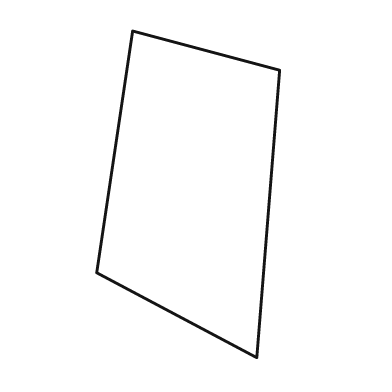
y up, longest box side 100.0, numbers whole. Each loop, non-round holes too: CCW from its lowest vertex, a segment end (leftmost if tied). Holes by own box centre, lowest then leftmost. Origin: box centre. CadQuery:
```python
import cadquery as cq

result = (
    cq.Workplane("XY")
    .moveTo(21.0, -50.0)
    .lineTo(28.0, 38.0)
    .lineTo(-17.0, 50.0)
    .lineTo(-28.0, -24.0)
    .close()
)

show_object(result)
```